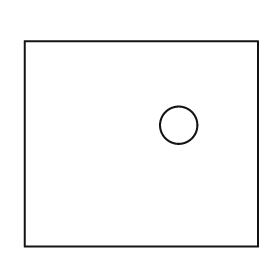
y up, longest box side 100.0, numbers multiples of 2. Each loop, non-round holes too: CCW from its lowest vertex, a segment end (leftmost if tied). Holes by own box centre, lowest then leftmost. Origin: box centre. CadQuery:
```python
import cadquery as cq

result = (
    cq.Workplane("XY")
    .moveTo(-50.0, -44.0)
    .lineTo(50.0, -44.0)
    .lineTo(50.0, 44.0)
    .lineTo(-50.0, 44.0)
    .close()
    .moveTo(16.0, 8.0)
    .circle(8.0)
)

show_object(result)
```